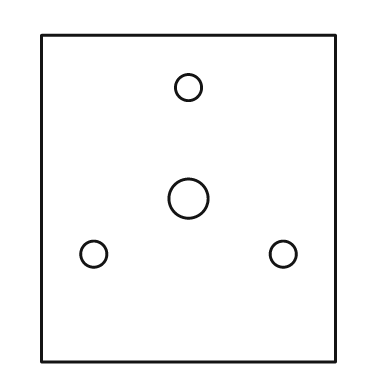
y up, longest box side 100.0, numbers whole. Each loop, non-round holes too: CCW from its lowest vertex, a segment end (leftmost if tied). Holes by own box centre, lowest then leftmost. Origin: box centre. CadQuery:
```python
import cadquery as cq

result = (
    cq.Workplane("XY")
    .moveTo(-45.0, -50.0)
    .lineTo(45.0, -50.0)
    .lineTo(45.0, 50.0)
    .lineTo(-45.0, 50.0)
    .close()
    .moveTo(-29.0, -17.0)
    .circle(4.0)
    .moveTo(29.0, -17.0)
    .circle(4.0)
    .moveTo(0.0, 0.0)
    .circle(6.0)
    .moveTo(0.0, 34.0)
    .circle(4.0)
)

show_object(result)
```